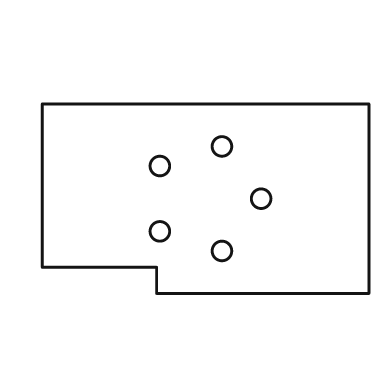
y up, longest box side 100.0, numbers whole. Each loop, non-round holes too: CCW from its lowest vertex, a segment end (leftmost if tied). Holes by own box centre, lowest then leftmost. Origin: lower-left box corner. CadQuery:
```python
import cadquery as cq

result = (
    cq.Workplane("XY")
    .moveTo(35.0, 0.0)
    .lineTo(100.0, 0.0)
    .lineTo(100.0, 58.0)
    .lineTo(0.0, 58.0)
    .lineTo(0.0, 8.0)
    .lineTo(35.0, 8.0)
    .close()
    .moveTo(55.0, 13.0)
    .circle(3.0)
    .moveTo(36.0, 19.0)
    .circle(3.0)
    .moveTo(67.0, 29.0)
    .circle(3.0)
    .moveTo(36.0, 39.0)
    .circle(3.0)
    .moveTo(55.0, 45.0)
    .circle(3.0)
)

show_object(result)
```